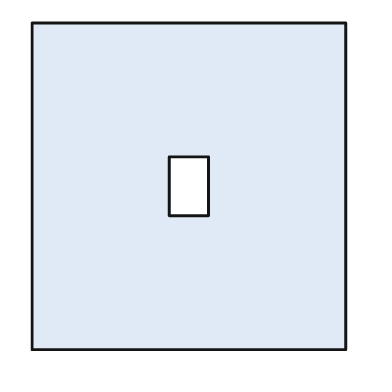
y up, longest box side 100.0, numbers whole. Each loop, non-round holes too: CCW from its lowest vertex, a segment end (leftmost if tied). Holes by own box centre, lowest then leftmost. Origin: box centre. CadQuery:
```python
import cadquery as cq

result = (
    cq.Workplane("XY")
    .moveTo(-48.0, -50.0)
    .lineTo(48.0, -50.0)
    .lineTo(48.0, 50.0)
    .lineTo(-48.0, 50.0)
    .close()
    .moveTo(-6.0, -9.0)
    .lineTo(6.0, -9.0)
    .lineTo(6.0, 9.0)
    .lineTo(-6.0, 9.0)
    .close()
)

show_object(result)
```